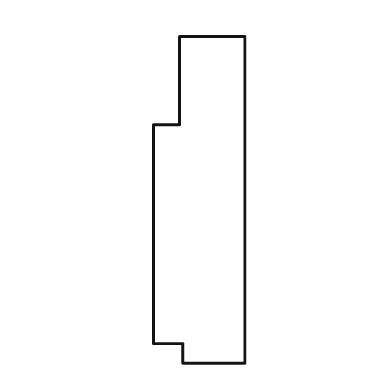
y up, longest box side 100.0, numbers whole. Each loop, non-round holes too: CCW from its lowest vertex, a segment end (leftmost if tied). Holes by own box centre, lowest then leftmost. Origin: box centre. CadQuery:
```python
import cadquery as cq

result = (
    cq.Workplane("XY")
    .moveTo(-5.0, -50.0)
    .lineTo(14.0, -50.0)
    .lineTo(14.0, 50.0)
    .lineTo(-6.0, 50.0)
    .lineTo(-6.0, 23.0)
    .lineTo(-14.0, 23.0)
    .lineTo(-14.0, -44.0)
    .lineTo(-5.0, -44.0)
    .close()
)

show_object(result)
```